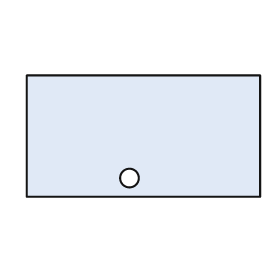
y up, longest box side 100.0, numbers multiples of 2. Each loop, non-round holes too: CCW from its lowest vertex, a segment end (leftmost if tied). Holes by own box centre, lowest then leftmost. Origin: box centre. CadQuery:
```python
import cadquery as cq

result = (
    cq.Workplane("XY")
    .moveTo(-50.0, -26.0)
    .lineTo(50.0, -26.0)
    .lineTo(50.0, 26.0)
    .lineTo(-50.0, 26.0)
    .close()
    .moveTo(-6.0, -18.0)
    .circle(4.0)
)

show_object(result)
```